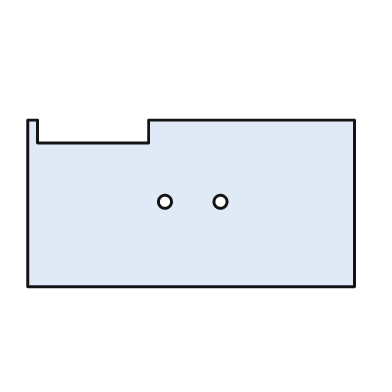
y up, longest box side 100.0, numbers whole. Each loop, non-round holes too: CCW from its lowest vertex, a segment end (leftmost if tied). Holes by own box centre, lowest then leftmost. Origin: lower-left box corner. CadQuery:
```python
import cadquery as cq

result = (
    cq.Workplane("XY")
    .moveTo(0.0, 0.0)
    .lineTo(100.0, 0.0)
    .lineTo(100.0, 51.0)
    .lineTo(37.0, 51.0)
    .lineTo(37.0, 44.0)
    .lineTo(3.0, 44.0)
    .lineTo(3.0, 51.0)
    .lineTo(0.0, 51.0)
    .close()
    .moveTo(42.0, 26.0)
    .circle(2.0)
    .moveTo(59.0, 26.0)
    .circle(2.0)
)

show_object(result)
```